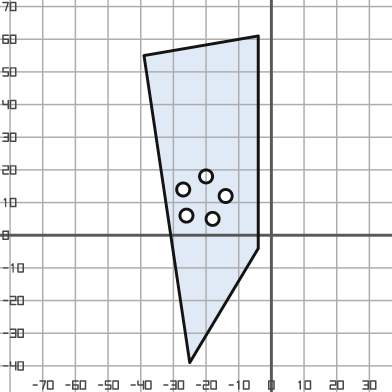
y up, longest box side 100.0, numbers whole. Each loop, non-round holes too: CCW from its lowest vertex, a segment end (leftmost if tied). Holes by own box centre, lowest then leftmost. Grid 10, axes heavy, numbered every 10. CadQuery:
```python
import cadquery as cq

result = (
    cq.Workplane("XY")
    .moveTo(-25.0, -39.0)
    .lineTo(-4.0, -4.0)
    .lineTo(-4.0, 61.0)
    .lineTo(-39.0, 55.0)
    .close()
    .moveTo(-18.0, 5.0)
    .circle(2.0)
    .moveTo(-26.0, 6.0)
    .circle(2.0)
    .moveTo(-14.0, 12.0)
    .circle(2.0)
    .moveTo(-27.0, 14.0)
    .circle(2.0)
    .moveTo(-20.0, 18.0)
    .circle(2.0)
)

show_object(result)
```